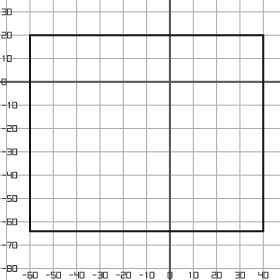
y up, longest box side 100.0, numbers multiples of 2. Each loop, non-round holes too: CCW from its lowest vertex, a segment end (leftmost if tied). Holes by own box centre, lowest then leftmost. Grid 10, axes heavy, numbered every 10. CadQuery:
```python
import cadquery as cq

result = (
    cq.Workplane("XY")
    .moveTo(-60.0, -64.0)
    .lineTo(40.0, -64.0)
    .lineTo(40.0, 20.0)
    .lineTo(-60.0, 20.0)
    .close()
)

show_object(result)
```